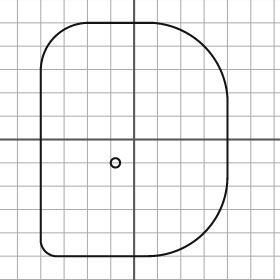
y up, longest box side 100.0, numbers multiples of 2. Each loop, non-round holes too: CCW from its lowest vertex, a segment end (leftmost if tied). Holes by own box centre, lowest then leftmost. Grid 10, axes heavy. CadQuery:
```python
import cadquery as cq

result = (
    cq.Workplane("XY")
    .moveTo(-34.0, -50.0)
    .lineTo(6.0, -50.0)
    .threePointArc((30.0, -40.0), (40.0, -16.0))
    .lineTo(40.0, 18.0)
    .threePointArc((30.0, 40.0), (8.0, 50.0))
    .lineTo(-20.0, 50.0)
    .threePointArc((-34.0, 44.0), (-40.0, 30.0))
    .lineTo(-40.0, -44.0)
    .threePointArc((-38.0, -48.0), (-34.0, -50.0))
    .close()
    .moveTo(-8.0, -10.0)
    .circle(2.0)
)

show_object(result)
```